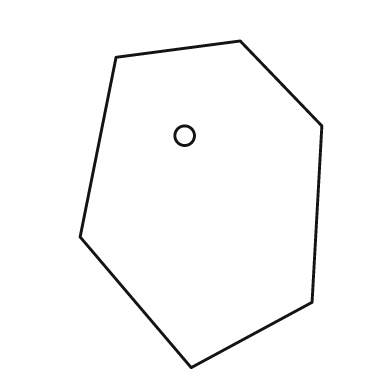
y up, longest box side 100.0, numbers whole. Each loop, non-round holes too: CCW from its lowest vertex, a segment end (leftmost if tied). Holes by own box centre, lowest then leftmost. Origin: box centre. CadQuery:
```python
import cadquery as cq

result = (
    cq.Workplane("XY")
    .moveTo(-3.0, -50.0)
    .lineTo(34.0, -30.0)
    .lineTo(37.0, 24.0)
    .lineTo(12.0, 50.0)
    .lineTo(-26.0, 45.0)
    .lineTo(-37.0, -10.0)
    .close()
    .moveTo(-5.0, 21.0)
    .circle(3.0)
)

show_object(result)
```